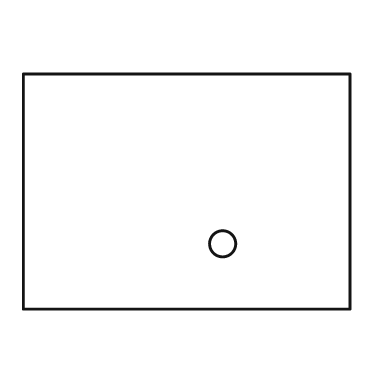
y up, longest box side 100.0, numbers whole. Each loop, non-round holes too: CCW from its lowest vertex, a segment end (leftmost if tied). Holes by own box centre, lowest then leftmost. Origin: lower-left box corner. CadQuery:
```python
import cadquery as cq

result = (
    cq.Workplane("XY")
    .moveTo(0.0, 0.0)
    .lineTo(100.0, 0.0)
    .lineTo(100.0, 72.0)
    .lineTo(0.0, 72.0)
    .close()
    .moveTo(61.0, 20.0)
    .circle(4.0)
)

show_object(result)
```